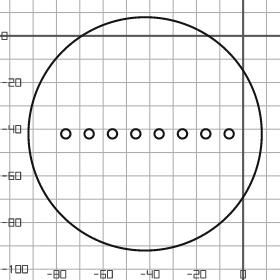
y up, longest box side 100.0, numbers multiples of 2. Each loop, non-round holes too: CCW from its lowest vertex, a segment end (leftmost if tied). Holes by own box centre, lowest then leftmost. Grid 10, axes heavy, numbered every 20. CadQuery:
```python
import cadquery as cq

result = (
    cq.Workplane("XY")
    .moveTo(-42.0, -42.0)
    .circle(50.0)
    .moveTo(-76.0, -42.0)
    .circle(2.0)
    .moveTo(-66.0, -42.0)
    .circle(2.0)
    .moveTo(-56.0, -42.0)
    .circle(2.0)
    .moveTo(-46.0, -42.0)
    .circle(2.0)
    .moveTo(-36.0, -42.0)
    .circle(2.0)
    .moveTo(-26.0, -42.0)
    .circle(2.0)
    .moveTo(-16.0, -42.0)
    .circle(2.0)
    .moveTo(-6.0, -42.0)
    .circle(2.0)
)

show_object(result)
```